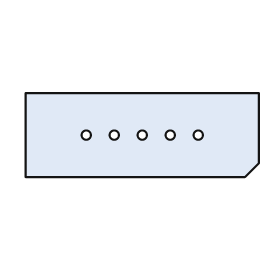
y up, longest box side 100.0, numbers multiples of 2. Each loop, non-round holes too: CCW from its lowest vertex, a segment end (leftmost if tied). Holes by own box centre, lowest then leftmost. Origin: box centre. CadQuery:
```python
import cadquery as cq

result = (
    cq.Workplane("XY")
    .moveTo(-50.0, -18.0)
    .lineTo(44.0, -18.0)
    .lineTo(50.0, -12.0)
    .lineTo(50.0, 18.0)
    .lineTo(-50.0, 18.0)
    .close()
    .moveTo(-24.0, 0.0)
    .circle(2.0)
    .moveTo(-12.0, 0.0)
    .circle(2.0)
    .moveTo(0.0, 0.0)
    .circle(2.0)
    .moveTo(12.0, 0.0)
    .circle(2.0)
    .moveTo(24.0, 0.0)
    .circle(2.0)
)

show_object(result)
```